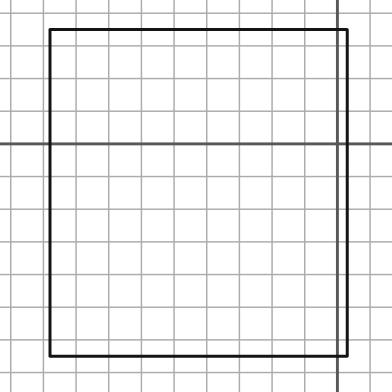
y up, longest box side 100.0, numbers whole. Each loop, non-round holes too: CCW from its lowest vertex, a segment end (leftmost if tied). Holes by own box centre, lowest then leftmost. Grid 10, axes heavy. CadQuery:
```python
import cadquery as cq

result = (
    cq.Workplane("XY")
    .moveTo(-88.0, -65.0)
    .lineTo(3.0, -65.0)
    .lineTo(3.0, 35.0)
    .lineTo(-88.0, 35.0)
    .close()
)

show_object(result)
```